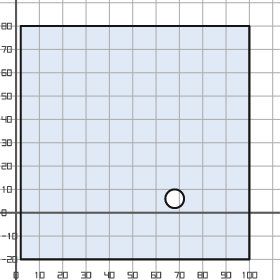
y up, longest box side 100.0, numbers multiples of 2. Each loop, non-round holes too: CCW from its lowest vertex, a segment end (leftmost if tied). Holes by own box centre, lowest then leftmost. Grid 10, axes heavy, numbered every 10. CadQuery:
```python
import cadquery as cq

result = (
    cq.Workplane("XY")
    .moveTo(2.0, -20.0)
    .lineTo(100.0, -20.0)
    .lineTo(100.0, 80.0)
    .lineTo(2.0, 80.0)
    .close()
    .moveTo(68.0, 6.0)
    .circle(4.0)
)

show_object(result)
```